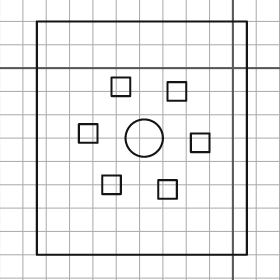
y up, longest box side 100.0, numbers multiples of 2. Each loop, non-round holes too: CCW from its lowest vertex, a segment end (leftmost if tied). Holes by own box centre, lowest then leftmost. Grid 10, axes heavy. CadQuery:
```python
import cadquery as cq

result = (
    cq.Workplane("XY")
    .moveTo(-84.0, -80.0)
    .lineTo(6.0, -80.0)
    .lineTo(6.0, 20.0)
    .lineTo(-84.0, 20.0)
    .close()
    .moveTo(-32.0, -56.0)
    .lineTo(-24.0, -56.0)
    .lineTo(-24.0, -48.0)
    .lineTo(-32.0, -48.0)
    .close()
    .moveTo(-56.0, -54.0)
    .lineTo(-48.0, -54.0)
    .lineTo(-48.0, -46.0)
    .lineTo(-56.0, -46.0)
    .close()
    .moveTo(-18.0, -36.0)
    .lineTo(-10.0, -36.0)
    .lineTo(-10.0, -28.0)
    .lineTo(-18.0, -28.0)
    .close()
    .moveTo(-38.0, -30.0)
    .circle(8.0)
    .moveTo(-66.0, -32.0)
    .lineTo(-58.0, -32.0)
    .lineTo(-58.0, -24.0)
    .lineTo(-66.0, -24.0)
    .close()
    .moveTo(-28.0, -14.0)
    .lineTo(-20.0, -14.0)
    .lineTo(-20.0, -6.0)
    .lineTo(-28.0, -6.0)
    .close()
    .moveTo(-52.0, -12.0)
    .lineTo(-44.0, -12.0)
    .lineTo(-44.0, -4.0)
    .lineTo(-52.0, -4.0)
    .close()
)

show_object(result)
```